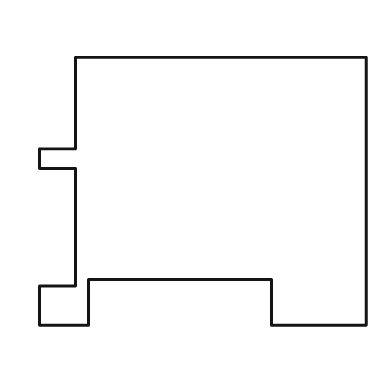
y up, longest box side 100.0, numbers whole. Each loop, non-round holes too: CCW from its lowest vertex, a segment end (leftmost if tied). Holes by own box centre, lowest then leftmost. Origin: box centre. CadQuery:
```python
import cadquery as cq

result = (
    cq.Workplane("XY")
    .moveTo(-50.0, -41.0)
    .lineTo(-35.0, -41.0)
    .lineTo(-35.0, -27.0)
    .lineTo(21.0, -27.0)
    .lineTo(21.0, -41.0)
    .lineTo(50.0, -41.0)
    .lineTo(50.0, 41.0)
    .lineTo(-39.0, 41.0)
    .lineTo(-39.0, 13.0)
    .lineTo(-50.0, 13.0)
    .lineTo(-50.0, 7.0)
    .lineTo(-39.0, 7.0)
    .lineTo(-39.0, -29.0)
    .lineTo(-50.0, -29.0)
    .close()
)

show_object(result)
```